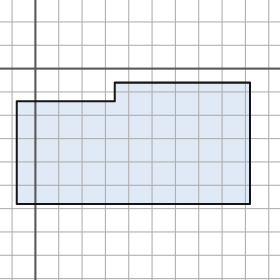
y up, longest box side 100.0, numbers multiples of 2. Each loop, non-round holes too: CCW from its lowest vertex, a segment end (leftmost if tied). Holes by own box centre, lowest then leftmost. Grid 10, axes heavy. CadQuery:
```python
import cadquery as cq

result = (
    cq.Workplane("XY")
    .moveTo(-8.0, -58.0)
    .lineTo(92.0, -58.0)
    .lineTo(92.0, -6.0)
    .lineTo(34.0, -6.0)
    .lineTo(34.0, -14.0)
    .lineTo(-8.0, -14.0)
    .close()
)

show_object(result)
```